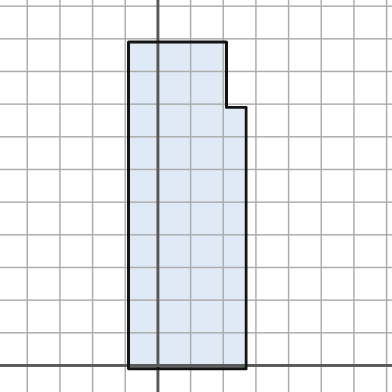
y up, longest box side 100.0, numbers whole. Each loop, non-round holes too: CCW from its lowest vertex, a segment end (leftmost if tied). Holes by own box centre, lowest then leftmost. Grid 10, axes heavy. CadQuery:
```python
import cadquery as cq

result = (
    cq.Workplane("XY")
    .moveTo(-9.0, -1.0)
    .lineTo(27.0, -1.0)
    .lineTo(27.0, 79.0)
    .lineTo(21.0, 79.0)
    .lineTo(21.0, 99.0)
    .lineTo(-9.0, 99.0)
    .close()
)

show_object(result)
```